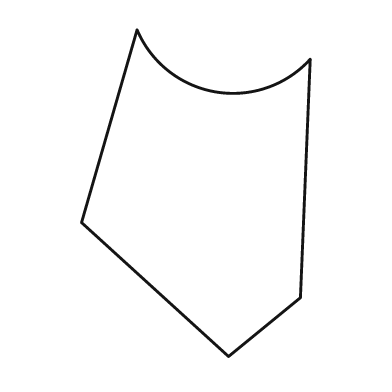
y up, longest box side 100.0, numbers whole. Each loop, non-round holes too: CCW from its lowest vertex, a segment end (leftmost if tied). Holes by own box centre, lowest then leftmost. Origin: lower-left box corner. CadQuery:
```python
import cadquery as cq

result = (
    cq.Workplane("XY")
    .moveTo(45.0, 0.0)
    .lineTo(67.0, 18.0)
    .lineTo(70.0, 91.0)
    .threePointArc((41.0, 81.0), (17.0, 100.0))
    .lineTo(0.0, 41.0)
    .close()
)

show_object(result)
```